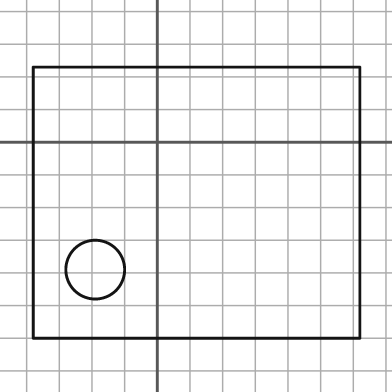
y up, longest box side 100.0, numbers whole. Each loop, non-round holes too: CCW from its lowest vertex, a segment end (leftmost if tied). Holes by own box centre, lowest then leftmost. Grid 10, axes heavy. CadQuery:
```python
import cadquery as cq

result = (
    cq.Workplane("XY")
    .moveTo(-38.0, -60.0)
    .lineTo(62.0, -60.0)
    .lineTo(62.0, 23.0)
    .lineTo(-38.0, 23.0)
    .close()
    .moveTo(-19.0, -39.0)
    .circle(9.0)
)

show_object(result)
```